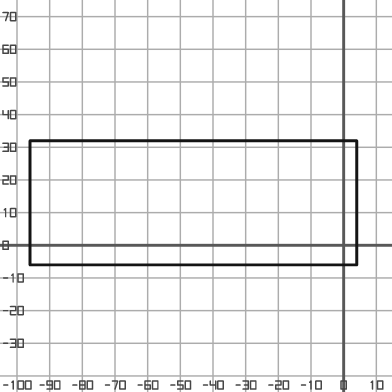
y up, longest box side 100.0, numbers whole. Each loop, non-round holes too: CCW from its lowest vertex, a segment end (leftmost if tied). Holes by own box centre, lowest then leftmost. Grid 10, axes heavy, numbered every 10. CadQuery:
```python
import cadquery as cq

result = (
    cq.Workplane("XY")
    .moveTo(-96.0, -6.0)
    .lineTo(4.0, -6.0)
    .lineTo(4.0, 32.0)
    .lineTo(-96.0, 32.0)
    .close()
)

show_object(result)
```